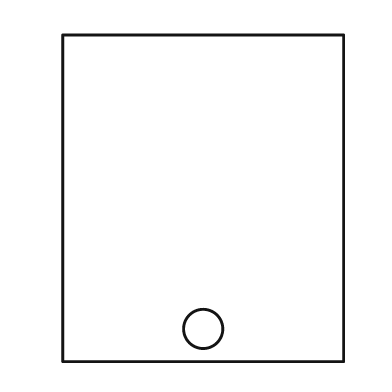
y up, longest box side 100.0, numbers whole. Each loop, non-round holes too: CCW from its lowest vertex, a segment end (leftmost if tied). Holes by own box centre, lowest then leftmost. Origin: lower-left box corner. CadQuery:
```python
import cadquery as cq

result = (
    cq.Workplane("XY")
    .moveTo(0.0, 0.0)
    .lineTo(86.0, 0.0)
    .lineTo(86.0, 100.0)
    .lineTo(0.0, 100.0)
    .close()
    .moveTo(43.0, 10.0)
    .circle(6.0)
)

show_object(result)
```